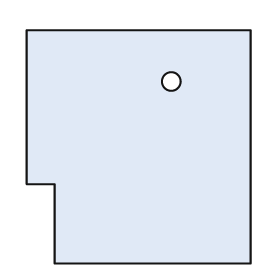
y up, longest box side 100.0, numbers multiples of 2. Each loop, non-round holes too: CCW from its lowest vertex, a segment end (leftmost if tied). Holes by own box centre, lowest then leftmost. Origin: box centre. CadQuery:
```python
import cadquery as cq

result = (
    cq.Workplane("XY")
    .moveTo(-36.0, -50.0)
    .lineTo(48.0, -50.0)
    .lineTo(48.0, 50.0)
    .lineTo(-48.0, 50.0)
    .lineTo(-48.0, -16.0)
    .lineTo(-36.0, -16.0)
    .close()
    .moveTo(14.0, 28.0)
    .circle(4.0)
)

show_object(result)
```